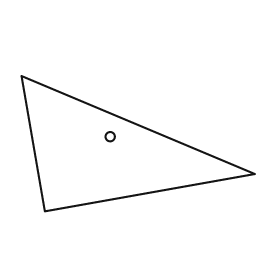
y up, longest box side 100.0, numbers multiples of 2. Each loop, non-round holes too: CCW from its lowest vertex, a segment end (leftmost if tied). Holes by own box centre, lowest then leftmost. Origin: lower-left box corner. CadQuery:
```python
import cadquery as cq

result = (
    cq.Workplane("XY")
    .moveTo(10.0, 0.0)
    .lineTo(100.0, 16.0)
    .lineTo(0.0, 58.0)
    .close()
    .moveTo(38.0, 32.0)
    .circle(2.0)
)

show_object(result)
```